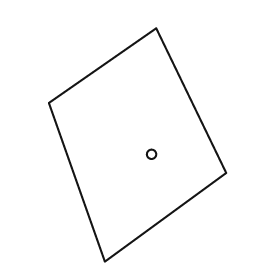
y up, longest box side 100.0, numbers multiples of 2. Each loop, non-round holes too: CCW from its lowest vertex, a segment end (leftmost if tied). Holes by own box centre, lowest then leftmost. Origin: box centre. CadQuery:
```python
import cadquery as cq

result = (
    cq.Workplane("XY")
    .moveTo(-14.0, -50.0)
    .lineTo(38.0, -12.0)
    .lineTo(8.0, 50.0)
    .lineTo(-38.0, 18.0)
    .close()
    .moveTo(6.0, -4.0)
    .circle(2.0)
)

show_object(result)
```